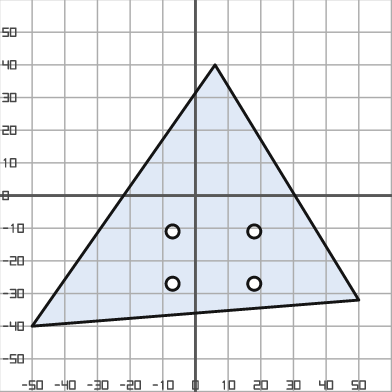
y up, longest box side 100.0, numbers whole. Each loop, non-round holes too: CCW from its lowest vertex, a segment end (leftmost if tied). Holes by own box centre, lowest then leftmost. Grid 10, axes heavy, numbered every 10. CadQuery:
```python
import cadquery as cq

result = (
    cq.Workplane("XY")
    .moveTo(-50.0, -40.0)
    .lineTo(50.0, -32.0)
    .lineTo(6.0, 40.0)
    .close()
    .moveTo(-7.0, -27.0)
    .circle(2.0)
    .moveTo(18.0, -27.0)
    .circle(2.0)
    .moveTo(-7.0, -11.0)
    .circle(2.0)
    .moveTo(18.0, -11.0)
    .circle(2.0)
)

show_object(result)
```